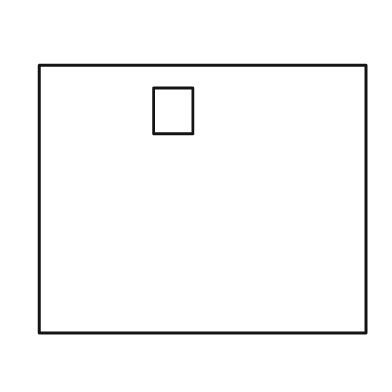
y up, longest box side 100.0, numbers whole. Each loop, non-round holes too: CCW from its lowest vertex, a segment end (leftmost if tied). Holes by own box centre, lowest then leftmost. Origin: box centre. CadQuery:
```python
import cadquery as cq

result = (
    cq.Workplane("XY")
    .moveTo(-50.0, -41.0)
    .lineTo(50.0, -41.0)
    .lineTo(50.0, 41.0)
    .lineTo(-50.0, 41.0)
    .close()
    .moveTo(-15.0, 20.0)
    .lineTo(-3.0, 20.0)
    .lineTo(-3.0, 34.0)
    .lineTo(-15.0, 34.0)
    .close()
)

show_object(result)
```